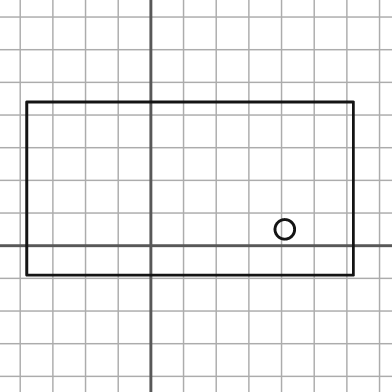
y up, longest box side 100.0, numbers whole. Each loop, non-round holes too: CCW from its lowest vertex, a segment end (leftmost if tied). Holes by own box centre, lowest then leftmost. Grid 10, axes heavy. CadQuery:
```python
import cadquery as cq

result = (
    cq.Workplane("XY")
    .moveTo(-38.0, -9.0)
    .lineTo(62.0, -9.0)
    .lineTo(62.0, 44.0)
    .lineTo(-38.0, 44.0)
    .close()
    .moveTo(41.0, 5.0)
    .circle(3.0)
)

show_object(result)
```